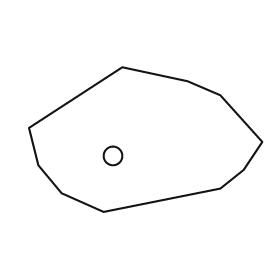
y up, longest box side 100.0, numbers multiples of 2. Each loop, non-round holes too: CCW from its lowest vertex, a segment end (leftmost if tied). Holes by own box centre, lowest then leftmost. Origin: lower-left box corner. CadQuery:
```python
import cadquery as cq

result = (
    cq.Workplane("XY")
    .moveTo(32.0, 0.0)
    .lineTo(82.0, 10.0)
    .lineTo(92.0, 18.0)
    .lineTo(100.0, 30.0)
    .lineTo(82.0, 50.0)
    .lineTo(68.0, 56.0)
    .lineTo(40.0, 62.0)
    .lineTo(0.0, 36.0)
    .lineTo(4.0, 20.0)
    .lineTo(14.0, 8.0)
    .close()
    .moveTo(36.0, 24.0)
    .circle(4.0)
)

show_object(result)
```